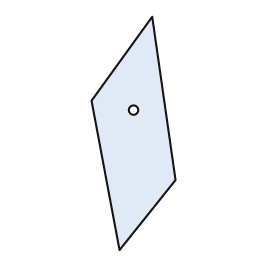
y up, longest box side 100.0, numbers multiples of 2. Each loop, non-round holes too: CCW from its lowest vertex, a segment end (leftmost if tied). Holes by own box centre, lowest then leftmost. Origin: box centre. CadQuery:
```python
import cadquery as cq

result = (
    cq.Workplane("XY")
    .moveTo(-6.0, -50.0)
    .lineTo(18.0, -20.0)
    .lineTo(8.0, 50.0)
    .lineTo(-18.0, 14.0)
    .close()
    .moveTo(0.0, 10.0)
    .circle(2.0)
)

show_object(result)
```